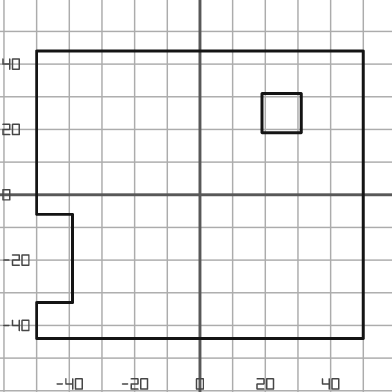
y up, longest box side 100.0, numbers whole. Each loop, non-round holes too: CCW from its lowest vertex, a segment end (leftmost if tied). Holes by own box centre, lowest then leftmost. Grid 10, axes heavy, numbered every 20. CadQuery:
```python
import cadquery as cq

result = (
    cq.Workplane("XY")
    .moveTo(-50.0, -44.0)
    .lineTo(50.0, -44.0)
    .lineTo(50.0, 44.0)
    .lineTo(-50.0, 44.0)
    .lineTo(-50.0, -6.0)
    .lineTo(-39.0, -6.0)
    .lineTo(-39.0, -33.0)
    .lineTo(-50.0, -33.0)
    .close()
    .moveTo(19.0, 19.0)
    .lineTo(31.0, 19.0)
    .lineTo(31.0, 31.0)
    .lineTo(19.0, 31.0)
    .close()
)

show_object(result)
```